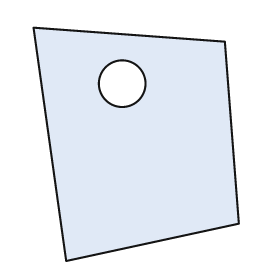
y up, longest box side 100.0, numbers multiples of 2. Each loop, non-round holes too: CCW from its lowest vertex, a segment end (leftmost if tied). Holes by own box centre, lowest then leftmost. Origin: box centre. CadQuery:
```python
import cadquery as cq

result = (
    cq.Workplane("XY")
    .moveTo(-30.0, -50.0)
    .lineTo(44.0, -34.0)
    .lineTo(38.0, 44.0)
    .lineTo(-44.0, 50.0)
    .close()
    .moveTo(-6.0, 26.0)
    .circle(10.0)
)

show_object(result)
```